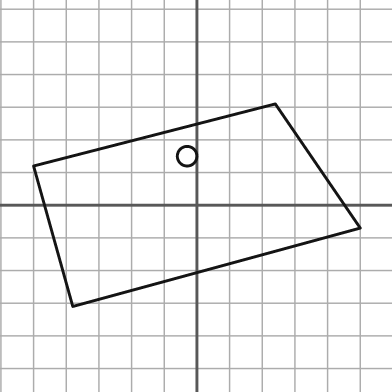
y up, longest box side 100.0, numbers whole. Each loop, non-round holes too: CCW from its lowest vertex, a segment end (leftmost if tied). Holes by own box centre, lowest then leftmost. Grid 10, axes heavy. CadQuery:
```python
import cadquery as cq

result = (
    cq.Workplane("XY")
    .moveTo(-38.0, -31.0)
    .lineTo(50.0, -7.0)
    .lineTo(24.0, 31.0)
    .lineTo(-50.0, 12.0)
    .close()
    .moveTo(-3.0, 15.0)
    .circle(3.0)
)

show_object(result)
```